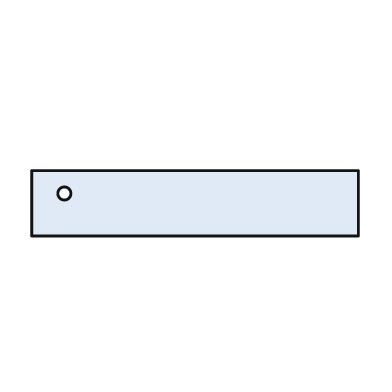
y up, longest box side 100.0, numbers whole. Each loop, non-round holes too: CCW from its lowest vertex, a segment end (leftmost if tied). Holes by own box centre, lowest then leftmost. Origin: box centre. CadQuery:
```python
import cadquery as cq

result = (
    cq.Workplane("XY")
    .moveTo(-50.0, -10.0)
    .lineTo(50.0, -10.0)
    .lineTo(50.0, 10.0)
    .lineTo(-50.0, 10.0)
    .close()
    .moveTo(-40.0, 3.0)
    .circle(2.0)
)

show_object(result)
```